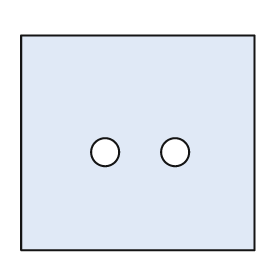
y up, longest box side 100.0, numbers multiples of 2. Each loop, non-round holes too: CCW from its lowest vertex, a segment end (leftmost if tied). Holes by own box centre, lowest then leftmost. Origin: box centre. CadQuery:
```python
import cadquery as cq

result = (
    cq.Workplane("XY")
    .moveTo(-50.0, -46.0)
    .lineTo(50.0, -46.0)
    .lineTo(50.0, 46.0)
    .lineTo(-50.0, 46.0)
    .close()
    .moveTo(-14.0, -4.0)
    .circle(6.0)
    .moveTo(16.0, -4.0)
    .circle(6.0)
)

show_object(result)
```